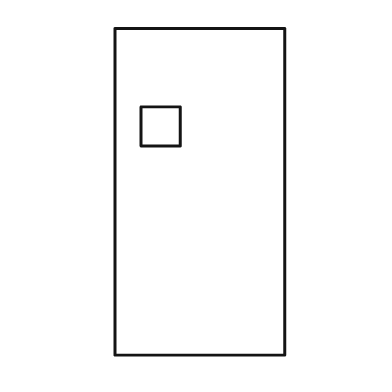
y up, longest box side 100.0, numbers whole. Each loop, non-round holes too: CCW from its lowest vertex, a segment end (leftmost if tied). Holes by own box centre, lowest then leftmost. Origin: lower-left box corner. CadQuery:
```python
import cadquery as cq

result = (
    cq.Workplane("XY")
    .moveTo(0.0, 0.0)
    .lineTo(52.0, 0.0)
    .lineTo(52.0, 100.0)
    .lineTo(0.0, 100.0)
    .close()
    .moveTo(8.0, 64.0)
    .lineTo(20.0, 64.0)
    .lineTo(20.0, 76.0)
    .lineTo(8.0, 76.0)
    .close()
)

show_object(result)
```